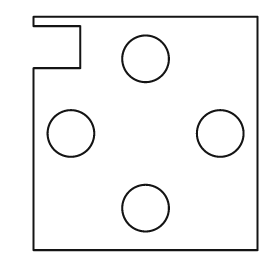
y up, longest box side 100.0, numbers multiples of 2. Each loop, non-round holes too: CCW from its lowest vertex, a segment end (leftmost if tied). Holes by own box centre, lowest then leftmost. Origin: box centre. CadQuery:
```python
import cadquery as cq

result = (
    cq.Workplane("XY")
    .moveTo(-48.0, -50.0)
    .lineTo(48.0, -50.0)
    .lineTo(48.0, 50.0)
    .lineTo(-48.0, 50.0)
    .lineTo(-48.0, 46.0)
    .lineTo(-28.0, 46.0)
    .lineTo(-28.0, 28.0)
    .lineTo(-48.0, 28.0)
    .close()
    .moveTo(0.0, -32.0)
    .circle(10.0)
    .moveTo(-32.0, 0.0)
    .circle(10.0)
    .moveTo(32.0, 0.0)
    .circle(10.0)
    .moveTo(0.0, 32.0)
    .circle(10.0)
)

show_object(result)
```